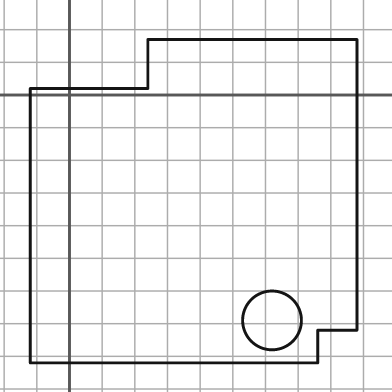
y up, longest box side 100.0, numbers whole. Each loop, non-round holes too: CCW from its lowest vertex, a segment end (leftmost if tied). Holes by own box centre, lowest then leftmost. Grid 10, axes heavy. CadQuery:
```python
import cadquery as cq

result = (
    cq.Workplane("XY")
    .moveTo(-12.0, -82.0)
    .lineTo(76.0, -82.0)
    .lineTo(76.0, -72.0)
    .lineTo(88.0, -72.0)
    .lineTo(88.0, 17.0)
    .lineTo(24.0, 17.0)
    .lineTo(24.0, 2.0)
    .lineTo(-12.0, 2.0)
    .close()
    .moveTo(62.0, -69.0)
    .circle(9.0)
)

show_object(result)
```